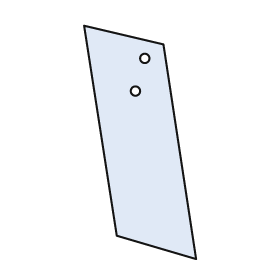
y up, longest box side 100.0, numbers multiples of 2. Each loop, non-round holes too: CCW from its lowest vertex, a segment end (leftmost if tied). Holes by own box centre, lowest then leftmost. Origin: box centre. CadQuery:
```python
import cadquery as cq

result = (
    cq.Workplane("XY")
    .moveTo(24.0, -50.0)
    .lineTo(10.0, 42.0)
    .lineTo(-24.0, 50.0)
    .lineTo(-10.0, -40.0)
    .close()
    .moveTo(-2.0, 22.0)
    .circle(2.0)
    .moveTo(2.0, 36.0)
    .circle(2.0)
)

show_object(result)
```